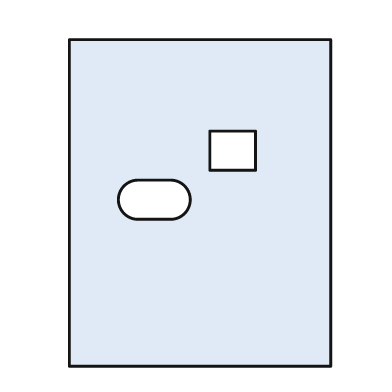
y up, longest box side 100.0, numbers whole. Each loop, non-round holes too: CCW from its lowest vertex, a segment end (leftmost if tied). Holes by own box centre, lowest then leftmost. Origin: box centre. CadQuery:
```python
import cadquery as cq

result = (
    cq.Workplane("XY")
    .moveTo(-40.0, -50.0)
    .lineTo(40.0, -50.0)
    .lineTo(40.0, 50.0)
    .lineTo(-40.0, 50.0)
    .close()
    .moveTo(-19.0, -5.0)
    .lineTo(-9.0, -5.0)
    .threePointArc((-3.0, 1.0), (-9.0, 7.0))
    .lineTo(-19.0, 7.0)
    .threePointArc((-25.0, 1.0), (-19.0, -5.0))
    .close()
    .moveTo(3.0, 10.0)
    .lineTo(17.0, 10.0)
    .lineTo(17.0, 22.0)
    .lineTo(3.0, 22.0)
    .close()
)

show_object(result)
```